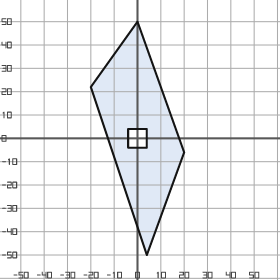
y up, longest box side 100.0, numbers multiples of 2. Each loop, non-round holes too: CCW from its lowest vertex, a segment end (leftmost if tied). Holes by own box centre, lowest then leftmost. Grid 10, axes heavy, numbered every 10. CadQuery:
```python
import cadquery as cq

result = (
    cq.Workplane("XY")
    .moveTo(4.0, -50.0)
    .lineTo(20.0, -6.0)
    .lineTo(0.0, 50.0)
    .lineTo(-20.0, 22.0)
    .close()
    .moveTo(-4.0, -4.0)
    .lineTo(4.0, -4.0)
    .lineTo(4.0, 4.0)
    .lineTo(-4.0, 4.0)
    .close()
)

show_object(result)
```